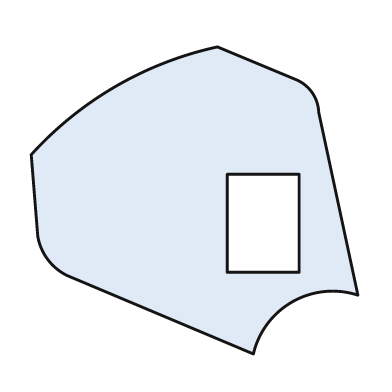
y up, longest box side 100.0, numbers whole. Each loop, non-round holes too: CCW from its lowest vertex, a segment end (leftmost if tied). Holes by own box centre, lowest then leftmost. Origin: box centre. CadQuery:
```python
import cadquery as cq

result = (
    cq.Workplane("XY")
    .moveTo(18.0, -47.0)
    .threePointArc((30.0, -31.0), (50.0, -29.0))
    .lineTo(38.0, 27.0)
    .threePointArc((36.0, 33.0), (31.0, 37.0))
    .lineTo(7.0, 47.0)
    .threePointArc((-24.0, 35.0), (-50.0, 14.0))
    .lineTo(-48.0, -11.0)
    .threePointArc((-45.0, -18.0), (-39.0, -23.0))
    .close()
    .moveTo(10.0, -22.0)
    .lineTo(32.0, -22.0)
    .lineTo(32.0, 8.0)
    .lineTo(10.0, 8.0)
    .close()
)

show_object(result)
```